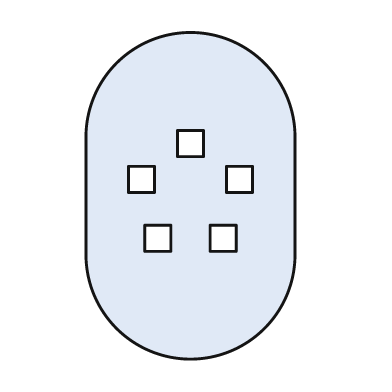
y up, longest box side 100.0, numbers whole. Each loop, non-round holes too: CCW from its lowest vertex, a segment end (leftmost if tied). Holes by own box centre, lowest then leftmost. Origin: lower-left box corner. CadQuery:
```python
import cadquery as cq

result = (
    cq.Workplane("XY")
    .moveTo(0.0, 32.0)
    .threePointArc((32.0, 0.0), (64.0, 32.0))
    .lineTo(64.0, 68.0)
    .threePointArc((32.0, 100.0), (0.0, 68.0))
    .close()
    .moveTo(18.0, 33.0)
    .lineTo(26.0, 33.0)
    .lineTo(26.0, 41.0)
    .lineTo(18.0, 41.0)
    .close()
    .moveTo(38.0, 33.0)
    .lineTo(46.0, 33.0)
    .lineTo(46.0, 41.0)
    .lineTo(38.0, 41.0)
    .close()
    .moveTo(13.0, 51.0)
    .lineTo(21.0, 51.0)
    .lineTo(21.0, 59.0)
    .lineTo(13.0, 59.0)
    .close()
    .moveTo(43.0, 51.0)
    .lineTo(51.0, 51.0)
    .lineTo(51.0, 59.0)
    .lineTo(43.0, 59.0)
    .close()
    .moveTo(28.0, 62.0)
    .lineTo(36.0, 62.0)
    .lineTo(36.0, 70.0)
    .lineTo(28.0, 70.0)
    .close()
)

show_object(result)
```